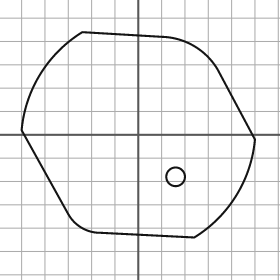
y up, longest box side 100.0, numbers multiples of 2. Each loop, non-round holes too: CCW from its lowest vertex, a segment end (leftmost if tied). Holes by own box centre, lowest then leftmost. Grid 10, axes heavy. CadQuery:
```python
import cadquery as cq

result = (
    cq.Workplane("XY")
    .moveTo(24.0, -44.0)
    .threePointArc((42.0, -26.0), (50.0, -2.0))
    .lineTo(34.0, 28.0)
    .threePointArc((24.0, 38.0), (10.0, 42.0))
    .lineTo(-24.0, 44.0)
    .threePointArc((-42.0, 26.0), (-50.0, 2.0))
    .lineTo(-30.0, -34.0)
    .threePointArc((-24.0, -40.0), (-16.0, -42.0))
    .close()
    .moveTo(16.0, -18.0)
    .circle(4.0)
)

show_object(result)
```